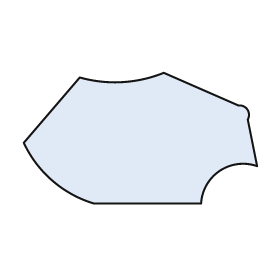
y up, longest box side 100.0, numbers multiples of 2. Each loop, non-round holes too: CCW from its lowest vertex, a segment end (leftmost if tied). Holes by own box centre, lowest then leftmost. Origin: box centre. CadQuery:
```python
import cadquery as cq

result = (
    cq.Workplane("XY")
    .moveTo(-20.0, -28.0)
    .lineTo(26.0, -28.0)
    .threePointArc((34.0, -14.0), (50.0, -12.0))
    .lineTo(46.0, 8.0)
    .threePointArc((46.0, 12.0), (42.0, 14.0))
    .lineTo(10.0, 28.0)
    .threePointArc((-8.0, 24.0), (-26.0, 26.0))
    .lineTo(-50.0, -2.0)
    .threePointArc((-38.0, -18.0), (-20.0, -28.0))
    .close()
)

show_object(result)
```